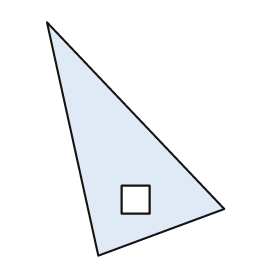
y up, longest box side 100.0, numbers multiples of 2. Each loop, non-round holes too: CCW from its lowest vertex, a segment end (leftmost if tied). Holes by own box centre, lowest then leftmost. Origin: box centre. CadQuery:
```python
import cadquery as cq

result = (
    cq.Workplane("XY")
    .moveTo(-16.0, -50.0)
    .lineTo(38.0, -30.0)
    .lineTo(-38.0, 50.0)
    .close()
    .moveTo(-6.0, -32.0)
    .lineTo(6.0, -32.0)
    .lineTo(6.0, -20.0)
    .lineTo(-6.0, -20.0)
    .close()
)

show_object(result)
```